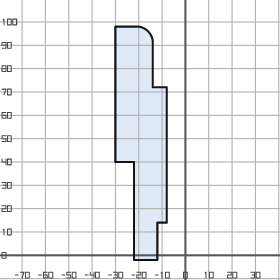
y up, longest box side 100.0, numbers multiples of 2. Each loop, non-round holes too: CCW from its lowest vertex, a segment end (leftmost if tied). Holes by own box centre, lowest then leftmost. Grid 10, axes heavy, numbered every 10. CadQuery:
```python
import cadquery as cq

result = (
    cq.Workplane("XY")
    .moveTo(-22.0, -2.0)
    .lineTo(-12.0, -2.0)
    .lineTo(-12.0, 14.0)
    .lineTo(-8.0, 14.0)
    .lineTo(-8.0, 72.0)
    .lineTo(-14.0, 72.0)
    .lineTo(-14.0, 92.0)
    .threePointArc((-16.0, 96.0), (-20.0, 98.0))
    .lineTo(-30.0, 98.0)
    .lineTo(-30.0, 40.0)
    .lineTo(-22.0, 40.0)
    .close()
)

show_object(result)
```